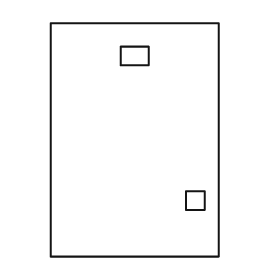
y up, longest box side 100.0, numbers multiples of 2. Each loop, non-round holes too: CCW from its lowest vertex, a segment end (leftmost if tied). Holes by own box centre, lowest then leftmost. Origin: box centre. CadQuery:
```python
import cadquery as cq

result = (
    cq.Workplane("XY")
    .moveTo(-36.0, -50.0)
    .lineTo(36.0, -50.0)
    .lineTo(36.0, 50.0)
    .lineTo(-36.0, 50.0)
    .close()
    .moveTo(22.0, -30.0)
    .lineTo(30.0, -30.0)
    .lineTo(30.0, -22.0)
    .lineTo(22.0, -22.0)
    .close()
    .moveTo(-6.0, 32.0)
    .lineTo(6.0, 32.0)
    .lineTo(6.0, 40.0)
    .lineTo(-6.0, 40.0)
    .close()
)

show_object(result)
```